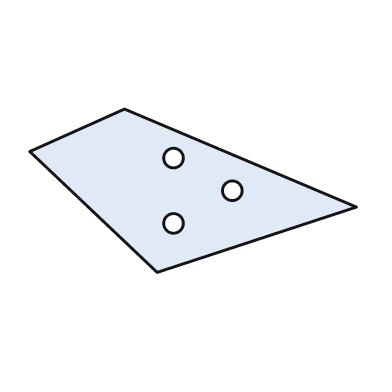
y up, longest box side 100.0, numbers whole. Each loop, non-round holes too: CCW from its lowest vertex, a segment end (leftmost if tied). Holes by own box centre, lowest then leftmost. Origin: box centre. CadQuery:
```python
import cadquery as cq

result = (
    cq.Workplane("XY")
    .moveTo(-11.0, -25.0)
    .lineTo(50.0, -5.0)
    .lineTo(-21.0, 25.0)
    .lineTo(-50.0, 12.0)
    .close()
    .moveTo(-6.0, -10.0)
    .circle(3.0)
    .moveTo(12.0, 0.0)
    .circle(3.0)
    .moveTo(-6.0, 10.0)
    .circle(3.0)
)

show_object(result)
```